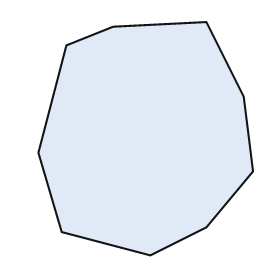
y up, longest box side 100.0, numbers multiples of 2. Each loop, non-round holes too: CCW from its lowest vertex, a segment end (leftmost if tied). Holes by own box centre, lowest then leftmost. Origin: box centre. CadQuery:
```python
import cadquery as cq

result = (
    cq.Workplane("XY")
    .moveTo(2.0, -50.0)
    .lineTo(26.0, -38.0)
    .lineTo(46.0, -14.0)
    .lineTo(42.0, 18.0)
    .lineTo(26.0, 50.0)
    .lineTo(-14.0, 48.0)
    .lineTo(-34.0, 40.0)
    .lineTo(-46.0, -6.0)
    .lineTo(-36.0, -40.0)
    .close()
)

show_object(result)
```